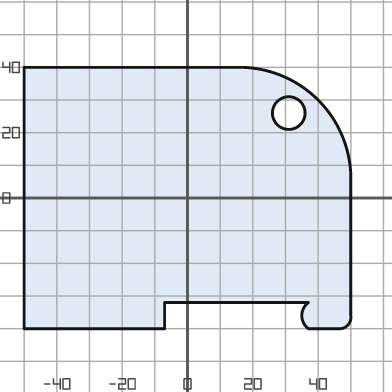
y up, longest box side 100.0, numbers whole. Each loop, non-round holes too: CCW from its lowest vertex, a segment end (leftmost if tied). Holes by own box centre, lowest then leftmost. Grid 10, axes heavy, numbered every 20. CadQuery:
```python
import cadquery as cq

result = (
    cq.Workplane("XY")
    .moveTo(-50.0, -40.0)
    .lineTo(-7.0, -40.0)
    .lineTo(-7.0, -32.0)
    .lineTo(37.0, -32.0)
    .threePointArc((35.0, -36.0), (37.0, -40.0))
    .lineTo(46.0, -40.0)
    .threePointArc((49.0, -39.0), (50.0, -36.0))
    .lineTo(50.0, 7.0)
    .threePointArc((40.0, 30.0), (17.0, 40.0))
    .lineTo(-50.0, 40.0)
    .close()
    .moveTo(31.0, 26.0)
    .circle(5.0)
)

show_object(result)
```